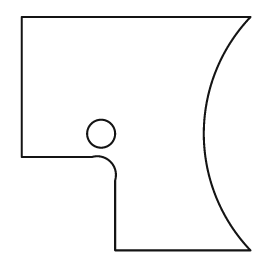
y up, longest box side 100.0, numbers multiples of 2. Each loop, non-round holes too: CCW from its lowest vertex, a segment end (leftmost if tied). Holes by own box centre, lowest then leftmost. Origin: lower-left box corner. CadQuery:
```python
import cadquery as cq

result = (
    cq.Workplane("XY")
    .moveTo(40.0, 0.0)
    .lineTo(98.0, 0.0)
    .threePointArc((78.0, 50.0), (98.0, 100.0))
    .lineTo(0.0, 100.0)
    .lineTo(0.0, 40.0)
    .lineTo(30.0, 40.0)
    .threePointArc((38.0, 38.0), (40.0, 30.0))
    .close()
    .moveTo(34.0, 50.0)
    .circle(6.0)
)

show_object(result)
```